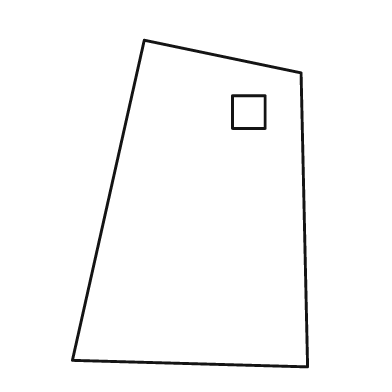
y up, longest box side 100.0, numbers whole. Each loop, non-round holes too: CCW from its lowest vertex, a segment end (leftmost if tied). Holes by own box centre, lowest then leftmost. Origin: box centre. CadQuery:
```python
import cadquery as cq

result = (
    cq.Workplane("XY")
    .moveTo(36.0, -50.0)
    .lineTo(34.0, 40.0)
    .lineTo(-14.0, 50.0)
    .lineTo(-36.0, -48.0)
    .close()
    .moveTo(13.0, 23.0)
    .lineTo(23.0, 23.0)
    .lineTo(23.0, 33.0)
    .lineTo(13.0, 33.0)
    .close()
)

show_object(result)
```